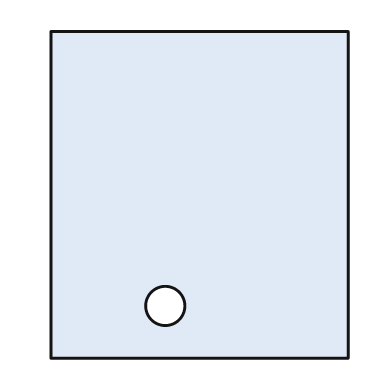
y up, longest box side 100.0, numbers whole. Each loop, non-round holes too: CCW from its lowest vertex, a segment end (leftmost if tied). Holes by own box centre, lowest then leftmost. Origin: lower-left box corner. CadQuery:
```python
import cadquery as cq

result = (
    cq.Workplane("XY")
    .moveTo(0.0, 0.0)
    .lineTo(91.0, 0.0)
    .lineTo(91.0, 100.0)
    .lineTo(0.0, 100.0)
    .close()
    .moveTo(35.0, 16.0)
    .circle(6.0)
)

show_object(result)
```